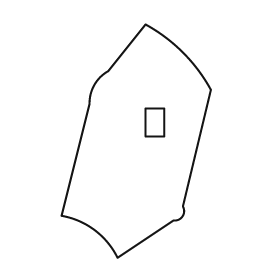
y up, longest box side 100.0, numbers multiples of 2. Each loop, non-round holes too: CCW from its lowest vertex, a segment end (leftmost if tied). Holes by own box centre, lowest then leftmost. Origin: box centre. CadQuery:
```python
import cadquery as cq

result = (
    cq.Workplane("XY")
    .moveTo(-8.0, -50.0)
    .lineTo(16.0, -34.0)
    .threePointArc((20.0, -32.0), (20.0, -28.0))
    .lineTo(32.0, 22.0)
    .threePointArc((20.0, 38.0), (4.0, 50.0))
    .lineTo(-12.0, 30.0)
    .threePointArc((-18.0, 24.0), (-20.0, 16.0))
    .lineTo(-32.0, -32.0)
    .threePointArc((-18.0, -38.0), (-8.0, -50.0))
    .close()
    .moveTo(4.0, 2.0)
    .lineTo(12.0, 2.0)
    .lineTo(12.0, 14.0)
    .lineTo(4.0, 14.0)
    .close()
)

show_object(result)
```